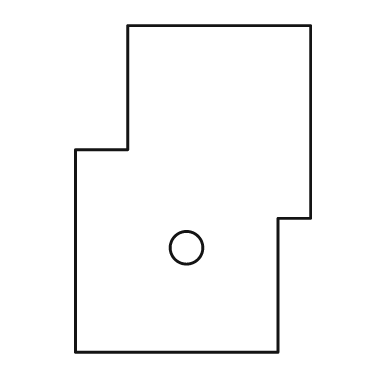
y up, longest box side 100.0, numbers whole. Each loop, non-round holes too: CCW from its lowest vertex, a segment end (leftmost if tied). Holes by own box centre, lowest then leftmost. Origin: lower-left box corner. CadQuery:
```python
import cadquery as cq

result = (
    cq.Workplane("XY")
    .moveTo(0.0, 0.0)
    .lineTo(62.0, 0.0)
    .lineTo(62.0, 41.0)
    .lineTo(72.0, 41.0)
    .lineTo(72.0, 100.0)
    .lineTo(16.0, 100.0)
    .lineTo(16.0, 62.0)
    .lineTo(0.0, 62.0)
    .close()
    .moveTo(34.0, 32.0)
    .circle(5.0)
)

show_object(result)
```